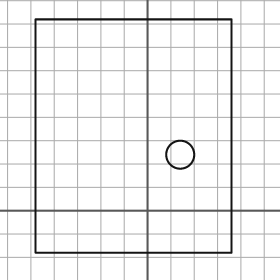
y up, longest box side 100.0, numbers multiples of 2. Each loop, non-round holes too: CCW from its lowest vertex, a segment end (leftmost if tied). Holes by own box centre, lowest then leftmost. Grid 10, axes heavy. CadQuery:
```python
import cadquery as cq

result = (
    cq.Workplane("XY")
    .moveTo(-48.0, -18.0)
    .lineTo(36.0, -18.0)
    .lineTo(36.0, 82.0)
    .lineTo(-48.0, 82.0)
    .close()
    .moveTo(14.0, 24.0)
    .circle(6.0)
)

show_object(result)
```